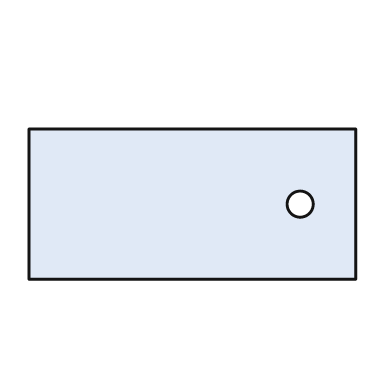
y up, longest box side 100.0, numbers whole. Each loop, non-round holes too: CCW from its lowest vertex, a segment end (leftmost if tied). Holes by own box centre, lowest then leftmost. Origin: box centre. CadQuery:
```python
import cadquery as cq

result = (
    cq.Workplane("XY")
    .moveTo(-50.0, -23.0)
    .lineTo(50.0, -23.0)
    .lineTo(50.0, 23.0)
    .lineTo(-50.0, 23.0)
    .close()
    .moveTo(33.0, 0.0)
    .circle(4.0)
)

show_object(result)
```